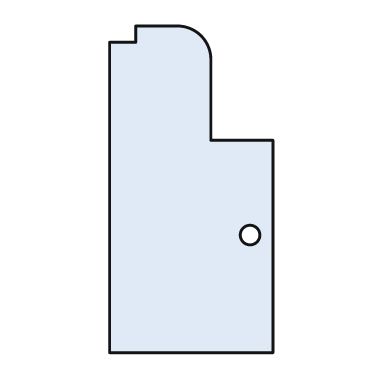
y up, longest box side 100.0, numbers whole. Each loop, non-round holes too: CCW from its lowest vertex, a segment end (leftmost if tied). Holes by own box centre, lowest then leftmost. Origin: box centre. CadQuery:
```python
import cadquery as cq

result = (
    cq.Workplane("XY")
    .moveTo(-25.0, -50.0)
    .lineTo(25.0, -50.0)
    .lineTo(25.0, 15.0)
    .lineTo(6.0, 15.0)
    .lineTo(6.0, 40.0)
    .threePointArc((3.0, 47.0), (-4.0, 50.0))
    .lineTo(-17.0, 50.0)
    .lineTo(-17.0, 45.0)
    .lineTo(-25.0, 45.0)
    .close()
    .moveTo(18.0, -14.0)
    .circle(3.0)
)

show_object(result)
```